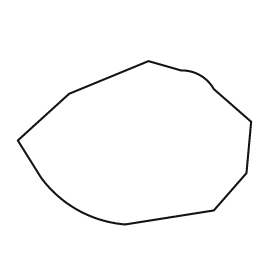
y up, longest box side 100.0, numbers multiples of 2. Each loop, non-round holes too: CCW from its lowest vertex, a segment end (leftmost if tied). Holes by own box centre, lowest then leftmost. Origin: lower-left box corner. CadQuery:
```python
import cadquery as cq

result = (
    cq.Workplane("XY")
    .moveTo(46.0, 0.0)
    .lineTo(84.0, 6.0)
    .lineTo(98.0, 22.0)
    .lineTo(100.0, 44.0)
    .lineTo(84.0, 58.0)
    .threePointArc((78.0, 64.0), (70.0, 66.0))
    .lineTo(56.0, 70.0)
    .lineTo(22.0, 56.0)
    .lineTo(0.0, 36.0)
    .lineTo(10.0, 20.0)
    .threePointArc((26.0, 6.0), (46.0, 0.0))
    .close()
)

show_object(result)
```